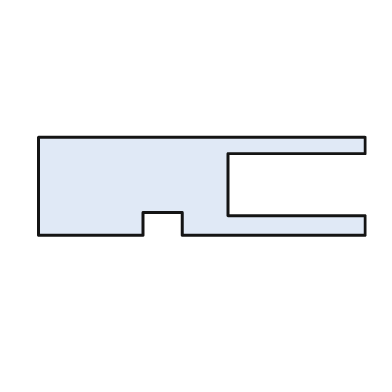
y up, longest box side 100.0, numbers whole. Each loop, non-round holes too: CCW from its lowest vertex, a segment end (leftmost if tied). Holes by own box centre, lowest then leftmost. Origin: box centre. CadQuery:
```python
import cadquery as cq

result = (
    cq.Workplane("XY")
    .moveTo(-50.0, -15.0)
    .lineTo(-18.0, -15.0)
    .lineTo(-18.0, -8.0)
    .lineTo(-6.0, -8.0)
    .lineTo(-6.0, -15.0)
    .lineTo(50.0, -15.0)
    .lineTo(50.0, -9.0)
    .lineTo(8.0, -9.0)
    .lineTo(8.0, 10.0)
    .lineTo(50.0, 10.0)
    .lineTo(50.0, 15.0)
    .lineTo(-50.0, 15.0)
    .close()
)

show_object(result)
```